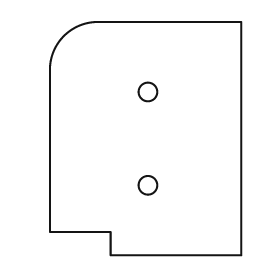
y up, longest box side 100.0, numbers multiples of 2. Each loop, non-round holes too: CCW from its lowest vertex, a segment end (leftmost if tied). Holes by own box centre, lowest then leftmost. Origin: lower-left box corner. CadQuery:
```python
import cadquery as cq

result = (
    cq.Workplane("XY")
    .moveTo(26.0, 0.0)
    .lineTo(82.0, 0.0)
    .lineTo(82.0, 100.0)
    .lineTo(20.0, 100.0)
    .threePointArc((6.0, 94.0), (0.0, 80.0))
    .lineTo(0.0, 10.0)
    .lineTo(26.0, 10.0)
    .close()
    .moveTo(42.0, 30.0)
    .circle(4.0)
    .moveTo(42.0, 70.0)
    .circle(4.0)
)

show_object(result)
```